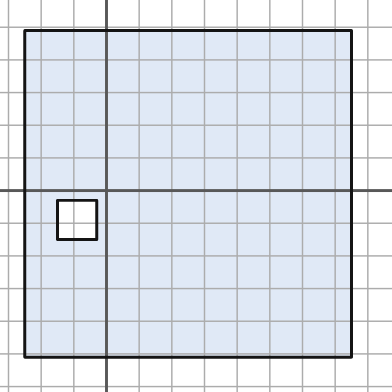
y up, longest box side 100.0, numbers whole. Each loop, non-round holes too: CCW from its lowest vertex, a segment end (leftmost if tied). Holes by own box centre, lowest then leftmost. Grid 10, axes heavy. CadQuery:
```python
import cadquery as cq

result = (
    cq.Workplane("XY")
    .moveTo(-25.0, -51.0)
    .lineTo(75.0, -51.0)
    .lineTo(75.0, 49.0)
    .lineTo(-25.0, 49.0)
    .close()
    .moveTo(-15.0, -15.0)
    .lineTo(-3.0, -15.0)
    .lineTo(-3.0, -3.0)
    .lineTo(-15.0, -3.0)
    .close()
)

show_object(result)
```